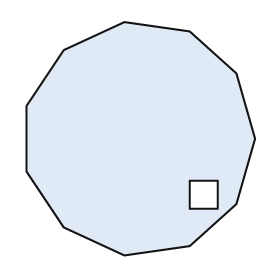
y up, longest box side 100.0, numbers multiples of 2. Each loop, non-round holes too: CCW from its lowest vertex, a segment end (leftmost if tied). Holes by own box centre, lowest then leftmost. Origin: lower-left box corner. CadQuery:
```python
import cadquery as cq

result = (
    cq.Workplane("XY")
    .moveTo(42.0, 0.0)
    .lineTo(70.0, 4.0)
    .lineTo(90.0, 22.0)
    .lineTo(98.0, 50.0)
    .lineTo(90.0, 78.0)
    .lineTo(70.0, 96.0)
    .lineTo(42.0, 100.0)
    .lineTo(16.0, 88.0)
    .lineTo(0.0, 64.0)
    .lineTo(0.0, 36.0)
    .lineTo(16.0, 12.0)
    .close()
    .moveTo(70.0, 20.0)
    .lineTo(82.0, 20.0)
    .lineTo(82.0, 32.0)
    .lineTo(70.0, 32.0)
    .close()
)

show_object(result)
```